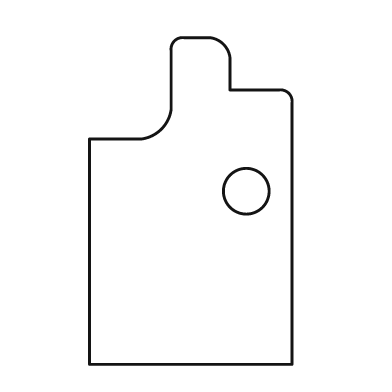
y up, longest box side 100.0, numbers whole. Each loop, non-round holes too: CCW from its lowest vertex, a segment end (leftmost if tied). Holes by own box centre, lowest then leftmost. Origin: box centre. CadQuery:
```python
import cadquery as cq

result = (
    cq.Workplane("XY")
    .moveTo(-31.0, -50.0)
    .lineTo(31.0, -50.0)
    .lineTo(31.0, 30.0)
    .threePointArc((30.0, 33.0), (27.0, 34.0))
    .lineTo(12.0, 34.0)
    .lineTo(12.0, 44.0)
    .threePointArc((10.0, 48.0), (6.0, 50.0))
    .lineTo(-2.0, 50.0)
    .threePointArc((-5.0, 49.0), (-6.0, 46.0))
    .lineTo(-6.0, 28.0)
    .threePointArc((-9.0, 22.0), (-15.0, 19.0))
    .lineTo(-31.0, 19.0)
    .close()
    .moveTo(17.0, 3.0)
    .circle(7.0)
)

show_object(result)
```